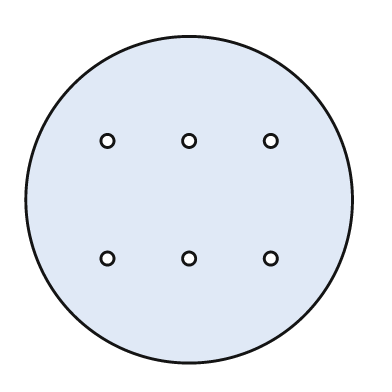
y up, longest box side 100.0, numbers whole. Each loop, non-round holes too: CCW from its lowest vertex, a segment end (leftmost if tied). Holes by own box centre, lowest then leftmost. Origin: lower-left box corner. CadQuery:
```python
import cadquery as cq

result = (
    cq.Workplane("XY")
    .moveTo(50.0, 50.0)
    .circle(50.0)
    .moveTo(25.0, 32.0)
    .circle(2.0)
    .moveTo(50.0, 32.0)
    .circle(2.0)
    .moveTo(75.0, 32.0)
    .circle(2.0)
    .moveTo(25.0, 68.0)
    .circle(2.0)
    .moveTo(50.0, 68.0)
    .circle(2.0)
    .moveTo(75.0, 68.0)
    .circle(2.0)
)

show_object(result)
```